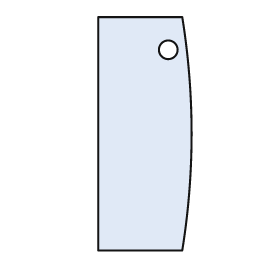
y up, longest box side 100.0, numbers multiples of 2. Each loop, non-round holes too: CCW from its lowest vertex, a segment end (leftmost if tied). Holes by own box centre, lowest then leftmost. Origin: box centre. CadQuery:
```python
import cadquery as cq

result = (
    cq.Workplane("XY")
    .moveTo(-20.0, -50.0)
    .lineTo(16.0, -50.0)
    .threePointArc((20.0, 0.0), (16.0, 50.0))
    .lineTo(-20.0, 50.0)
    .close()
    .moveTo(10.0, 36.0)
    .circle(4.0)
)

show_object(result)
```